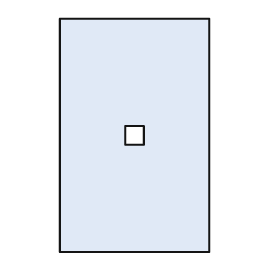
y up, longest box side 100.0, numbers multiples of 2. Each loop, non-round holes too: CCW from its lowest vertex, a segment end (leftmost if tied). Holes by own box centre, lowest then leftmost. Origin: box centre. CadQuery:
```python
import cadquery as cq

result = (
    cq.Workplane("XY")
    .moveTo(-32.0, -50.0)
    .lineTo(32.0, -50.0)
    .lineTo(32.0, 50.0)
    .lineTo(-32.0, 50.0)
    .close()
    .moveTo(-4.0, -4.0)
    .lineTo(4.0, -4.0)
    .lineTo(4.0, 4.0)
    .lineTo(-4.0, 4.0)
    .close()
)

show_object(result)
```